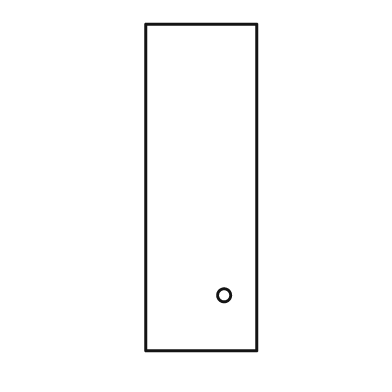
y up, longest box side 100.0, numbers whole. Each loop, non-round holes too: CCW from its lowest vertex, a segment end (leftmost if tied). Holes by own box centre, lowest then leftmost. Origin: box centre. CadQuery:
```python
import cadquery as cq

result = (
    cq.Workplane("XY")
    .moveTo(-17.0, -50.0)
    .lineTo(17.0, -50.0)
    .lineTo(17.0, 50.0)
    .lineTo(-17.0, 50.0)
    .close()
    .moveTo(7.0, -33.0)
    .circle(2.0)
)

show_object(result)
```